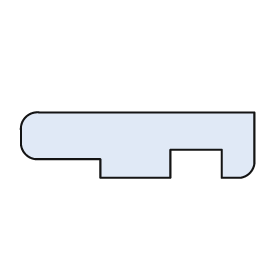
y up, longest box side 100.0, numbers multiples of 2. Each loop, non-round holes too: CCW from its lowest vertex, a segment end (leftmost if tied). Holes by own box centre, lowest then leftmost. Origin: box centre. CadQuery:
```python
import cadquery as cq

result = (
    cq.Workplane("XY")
    .moveTo(-16.0, -14.0)
    .lineTo(14.0, -14.0)
    .lineTo(14.0, -2.0)
    .lineTo(36.0, -2.0)
    .lineTo(36.0, -14.0)
    .lineTo(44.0, -14.0)
    .threePointArc((48.0, -12.0), (50.0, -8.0))
    .lineTo(50.0, 14.0)
    .lineTo(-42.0, 14.0)
    .threePointArc((-48.0, 12.0), (-50.0, 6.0))
    .lineTo(-50.0, 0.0)
    .threePointArc((-48.0, -4.0), (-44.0, -6.0))
    .lineTo(-16.0, -6.0)
    .close()
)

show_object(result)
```